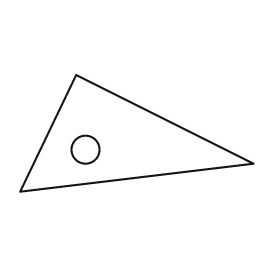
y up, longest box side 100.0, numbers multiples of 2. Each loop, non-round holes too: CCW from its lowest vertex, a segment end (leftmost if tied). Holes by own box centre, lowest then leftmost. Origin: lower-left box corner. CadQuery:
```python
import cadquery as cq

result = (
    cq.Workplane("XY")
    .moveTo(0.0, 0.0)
    .lineTo(100.0, 12.0)
    .lineTo(24.0, 50.0)
    .close()
    .moveTo(28.0, 18.0)
    .circle(6.0)
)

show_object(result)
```